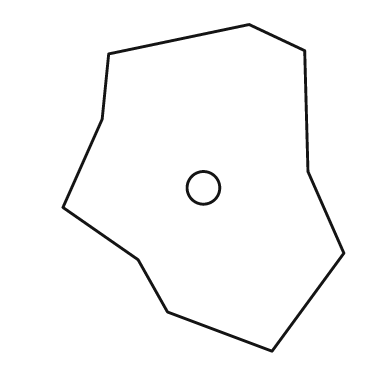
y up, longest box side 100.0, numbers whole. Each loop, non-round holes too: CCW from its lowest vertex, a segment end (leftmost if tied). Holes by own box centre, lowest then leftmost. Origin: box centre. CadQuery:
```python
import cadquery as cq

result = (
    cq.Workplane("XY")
    .moveTo(21.0, -50.0)
    .lineTo(43.0, -20.0)
    .lineTo(32.0, 5.0)
    .lineTo(31.0, 42.0)
    .lineTo(14.0, 50.0)
    .lineTo(-29.0, 41.0)
    .lineTo(-31.0, 21.0)
    .lineTo(-43.0, -6.0)
    .lineTo(-20.0, -22.0)
    .lineTo(-11.0, -38.0)
    .close()
    .moveTo(0.0, 0.0)
    .circle(5.0)
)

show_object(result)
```